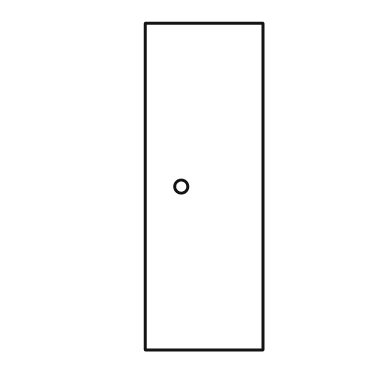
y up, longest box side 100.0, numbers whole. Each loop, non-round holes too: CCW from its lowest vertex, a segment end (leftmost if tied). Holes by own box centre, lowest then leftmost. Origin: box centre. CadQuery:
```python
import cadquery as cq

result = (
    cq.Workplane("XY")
    .moveTo(-18.0, -50.0)
    .lineTo(18.0, -50.0)
    .lineTo(18.0, 50.0)
    .lineTo(-18.0, 50.0)
    .close()
    .moveTo(-7.0, 0.0)
    .circle(2.0)
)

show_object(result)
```